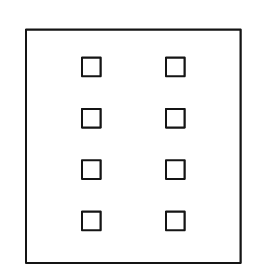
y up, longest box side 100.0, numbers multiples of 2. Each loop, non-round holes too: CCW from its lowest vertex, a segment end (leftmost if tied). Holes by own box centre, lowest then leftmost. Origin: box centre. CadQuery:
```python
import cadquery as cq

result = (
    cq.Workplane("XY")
    .moveTo(-46.0, -50.0)
    .lineTo(46.0, -50.0)
    .lineTo(46.0, 50.0)
    .lineTo(-46.0, 50.0)
    .close()
    .moveTo(-22.0, -36.0)
    .lineTo(-14.0, -36.0)
    .lineTo(-14.0, -28.0)
    .lineTo(-22.0, -28.0)
    .close()
    .moveTo(14.0, -36.0)
    .lineTo(22.0, -36.0)
    .lineTo(22.0, -28.0)
    .lineTo(14.0, -28.0)
    .close()
    .moveTo(-22.0, -14.0)
    .lineTo(-14.0, -14.0)
    .lineTo(-14.0, -6.0)
    .lineTo(-22.0, -6.0)
    .close()
    .moveTo(14.0, -14.0)
    .lineTo(22.0, -14.0)
    .lineTo(22.0, -6.0)
    .lineTo(14.0, -6.0)
    .close()
    .moveTo(-22.0, 8.0)
    .lineTo(-14.0, 8.0)
    .lineTo(-14.0, 16.0)
    .lineTo(-22.0, 16.0)
    .close()
    .moveTo(14.0, 8.0)
    .lineTo(22.0, 8.0)
    .lineTo(22.0, 16.0)
    .lineTo(14.0, 16.0)
    .close()
    .moveTo(-22.0, 30.0)
    .lineTo(-14.0, 30.0)
    .lineTo(-14.0, 38.0)
    .lineTo(-22.0, 38.0)
    .close()
    .moveTo(14.0, 30.0)
    .lineTo(22.0, 30.0)
    .lineTo(22.0, 38.0)
    .lineTo(14.0, 38.0)
    .close()
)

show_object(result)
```